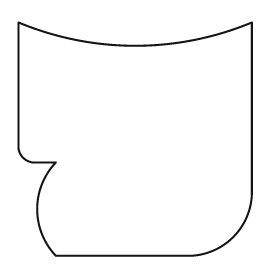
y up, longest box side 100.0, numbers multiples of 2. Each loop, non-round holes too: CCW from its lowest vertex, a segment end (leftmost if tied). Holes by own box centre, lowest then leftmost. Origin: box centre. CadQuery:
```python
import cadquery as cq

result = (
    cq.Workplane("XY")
    .moveTo(-34.0, -50.0)
    .lineTo(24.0, -50.0)
    .threePointArc((42.0, -42.0), (50.0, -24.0))
    .lineTo(50.0, 50.0)
    .threePointArc((0.0, 40.0), (-50.0, 50.0))
    .lineTo(-50.0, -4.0)
    .threePointArc((-48.0, -8.0), (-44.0, -10.0))
    .lineTo(-34.0, -10.0)
    .threePointArc((-42.0, -30.0), (-34.0, -50.0))
    .close()
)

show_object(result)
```